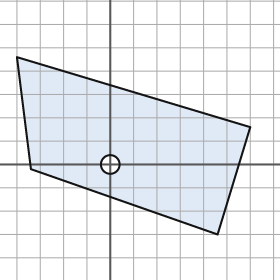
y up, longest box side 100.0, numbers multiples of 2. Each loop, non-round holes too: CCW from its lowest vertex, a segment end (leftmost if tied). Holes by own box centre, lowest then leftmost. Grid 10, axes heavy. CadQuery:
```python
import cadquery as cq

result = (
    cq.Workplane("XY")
    .moveTo(46.0, -30.0)
    .lineTo(60.0, 16.0)
    .lineTo(-40.0, 46.0)
    .lineTo(-34.0, -2.0)
    .close()
    .moveTo(0.0, 0.0)
    .circle(4.0)
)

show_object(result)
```